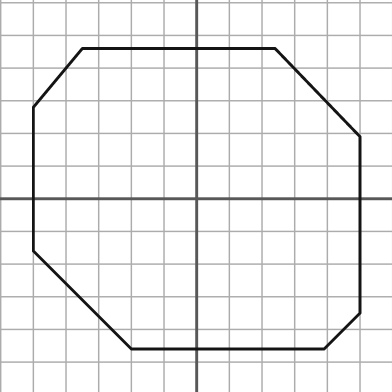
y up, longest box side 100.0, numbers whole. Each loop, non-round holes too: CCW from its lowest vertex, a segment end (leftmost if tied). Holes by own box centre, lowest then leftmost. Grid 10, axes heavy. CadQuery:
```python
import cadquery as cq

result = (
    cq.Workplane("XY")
    .moveTo(-20.0, -46.0)
    .lineTo(39.0, -46.0)
    .lineTo(50.0, -35.0)
    .lineTo(50.0, 19.0)
    .lineTo(24.0, 46.0)
    .lineTo(-35.0, 46.0)
    .lineTo(-50.0, 28.0)
    .lineTo(-50.0, -16.0)
    .close()
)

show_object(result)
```